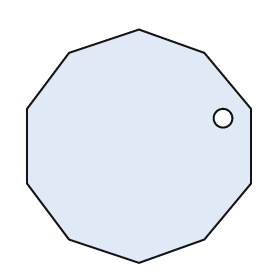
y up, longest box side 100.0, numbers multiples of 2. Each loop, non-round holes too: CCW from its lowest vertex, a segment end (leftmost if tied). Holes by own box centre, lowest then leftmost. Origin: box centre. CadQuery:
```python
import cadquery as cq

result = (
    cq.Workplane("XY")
    .moveTo(0.0, -50.0)
    .lineTo(28.0, -40.0)
    .lineTo(48.0, -16.0)
    .lineTo(48.0, 16.0)
    .lineTo(28.0, 40.0)
    .lineTo(0.0, 50.0)
    .lineTo(-30.0, 40.0)
    .lineTo(-48.0, 16.0)
    .lineTo(-48.0, -16.0)
    .lineTo(-30.0, -40.0)
    .close()
    .moveTo(36.0, 12.0)
    .circle(4.0)
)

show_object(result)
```